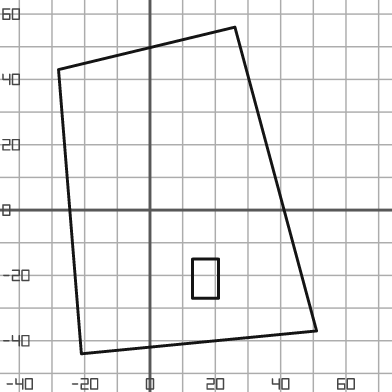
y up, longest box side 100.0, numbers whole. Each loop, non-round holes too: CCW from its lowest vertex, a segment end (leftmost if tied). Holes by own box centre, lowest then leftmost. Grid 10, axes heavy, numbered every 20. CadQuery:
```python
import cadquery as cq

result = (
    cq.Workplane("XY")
    .moveTo(-21.0, -44.0)
    .lineTo(51.0, -37.0)
    .lineTo(26.0, 56.0)
    .lineTo(-28.0, 43.0)
    .close()
    .moveTo(13.0, -27.0)
    .lineTo(21.0, -27.0)
    .lineTo(21.0, -15.0)
    .lineTo(13.0, -15.0)
    .close()
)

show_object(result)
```